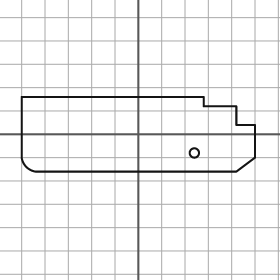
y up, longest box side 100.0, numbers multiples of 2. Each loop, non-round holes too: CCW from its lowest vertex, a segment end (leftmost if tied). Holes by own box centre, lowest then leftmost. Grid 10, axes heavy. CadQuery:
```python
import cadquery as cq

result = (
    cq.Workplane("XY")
    .moveTo(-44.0, -16.0)
    .lineTo(42.0, -16.0)
    .lineTo(50.0, -10.0)
    .lineTo(50.0, 4.0)
    .lineTo(42.0, 4.0)
    .lineTo(42.0, 12.0)
    .lineTo(28.0, 12.0)
    .lineTo(28.0, 16.0)
    .lineTo(-50.0, 16.0)
    .lineTo(-50.0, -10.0)
    .threePointArc((-48.0, -14.0), (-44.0, -16.0))
    .close()
    .moveTo(24.0, -8.0)
    .circle(2.0)
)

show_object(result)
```